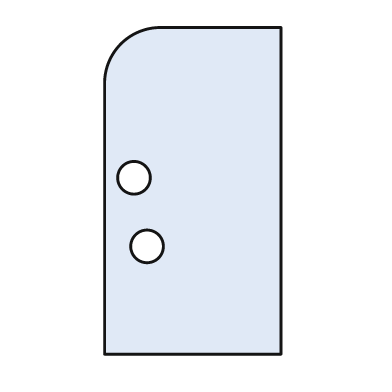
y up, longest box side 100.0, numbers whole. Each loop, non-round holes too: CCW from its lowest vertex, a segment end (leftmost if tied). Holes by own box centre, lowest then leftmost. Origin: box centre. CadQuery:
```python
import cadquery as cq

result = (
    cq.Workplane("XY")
    .moveTo(-27.0, -50.0)
    .lineTo(27.0, -50.0)
    .lineTo(27.0, 50.0)
    .lineTo(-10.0, 50.0)
    .threePointArc((-22.0, 45.0), (-27.0, 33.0))
    .close()
    .moveTo(-14.0, -17.0)
    .circle(5.0)
    .moveTo(-18.0, 4.0)
    .circle(5.0)
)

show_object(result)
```